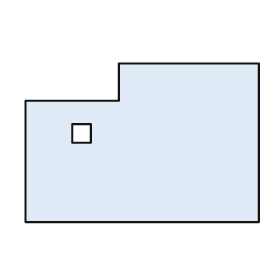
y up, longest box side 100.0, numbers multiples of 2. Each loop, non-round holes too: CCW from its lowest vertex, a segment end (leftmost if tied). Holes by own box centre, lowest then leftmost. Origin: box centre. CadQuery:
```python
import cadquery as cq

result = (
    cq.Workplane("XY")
    .moveTo(-50.0, -34.0)
    .lineTo(50.0, -34.0)
    .lineTo(50.0, 34.0)
    .lineTo(-10.0, 34.0)
    .lineTo(-10.0, 18.0)
    .lineTo(-50.0, 18.0)
    .close()
    .moveTo(-30.0, 0.0)
    .lineTo(-22.0, 0.0)
    .lineTo(-22.0, 8.0)
    .lineTo(-30.0, 8.0)
    .close()
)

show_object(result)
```